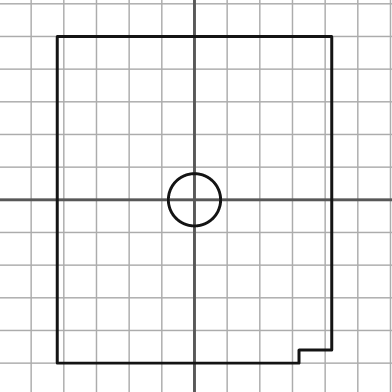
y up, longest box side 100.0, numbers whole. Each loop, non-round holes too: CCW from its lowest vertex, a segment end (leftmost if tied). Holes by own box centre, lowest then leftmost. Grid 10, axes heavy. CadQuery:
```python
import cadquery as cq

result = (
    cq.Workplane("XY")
    .moveTo(-42.0, -50.0)
    .lineTo(32.0, -50.0)
    .lineTo(32.0, -46.0)
    .lineTo(42.0, -46.0)
    .lineTo(42.0, 50.0)
    .lineTo(-42.0, 50.0)
    .close()
    .moveTo(0.0, 0.0)
    .circle(8.0)
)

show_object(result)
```